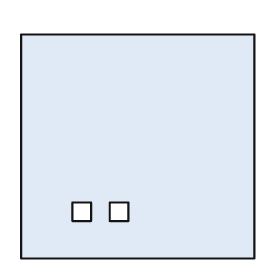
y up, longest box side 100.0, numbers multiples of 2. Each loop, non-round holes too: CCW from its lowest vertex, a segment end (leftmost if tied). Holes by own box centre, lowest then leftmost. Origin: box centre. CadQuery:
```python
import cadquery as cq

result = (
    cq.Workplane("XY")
    .moveTo(-50.0, -48.0)
    .lineTo(50.0, -48.0)
    .lineTo(50.0, 48.0)
    .lineTo(-50.0, 48.0)
    .close()
    .moveTo(-28.0, -32.0)
    .lineTo(-20.0, -32.0)
    .lineTo(-20.0, -24.0)
    .lineTo(-28.0, -24.0)
    .close()
    .moveTo(-12.0, -32.0)
    .lineTo(-4.0, -32.0)
    .lineTo(-4.0, -24.0)
    .lineTo(-12.0, -24.0)
    .close()
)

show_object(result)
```